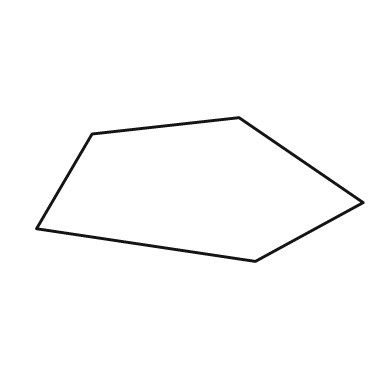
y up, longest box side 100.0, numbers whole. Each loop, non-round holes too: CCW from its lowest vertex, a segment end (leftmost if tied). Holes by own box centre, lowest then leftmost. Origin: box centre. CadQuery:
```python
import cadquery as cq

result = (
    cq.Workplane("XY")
    .moveTo(17.0, -22.0)
    .lineTo(50.0, -4.0)
    .lineTo(12.0, 22.0)
    .lineTo(-33.0, 17.0)
    .lineTo(-50.0, -12.0)
    .close()
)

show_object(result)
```